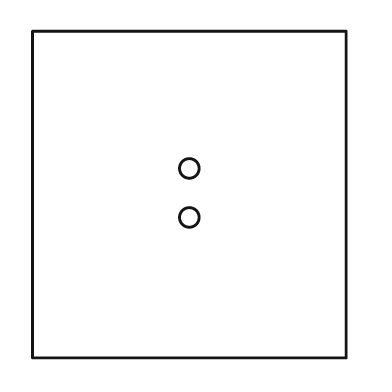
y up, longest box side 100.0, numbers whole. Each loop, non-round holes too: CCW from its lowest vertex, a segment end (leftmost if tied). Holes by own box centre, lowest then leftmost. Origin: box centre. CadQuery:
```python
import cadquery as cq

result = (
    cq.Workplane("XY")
    .moveTo(-48.0, -50.0)
    .lineTo(48.0, -50.0)
    .lineTo(48.0, 50.0)
    .lineTo(-48.0, 50.0)
    .close()
    .moveTo(0.0, -7.0)
    .circle(3.0)
    .moveTo(0.0, 8.0)
    .circle(3.0)
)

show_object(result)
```